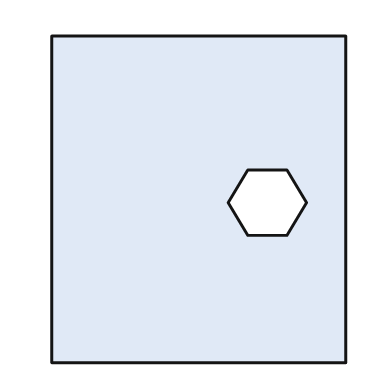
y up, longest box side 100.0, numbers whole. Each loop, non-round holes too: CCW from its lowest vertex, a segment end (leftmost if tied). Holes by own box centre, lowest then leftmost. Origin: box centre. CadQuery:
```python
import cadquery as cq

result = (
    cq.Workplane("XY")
    .moveTo(-45.0, -50.0)
    .lineTo(45.0, -50.0)
    .lineTo(45.0, 50.0)
    .lineTo(-45.0, 50.0)
    .close()
    .moveTo(15.0, -11.0)
    .lineTo(27.0, -11.0)
    .lineTo(33.0, -1.0)
    .lineTo(27.0, 9.0)
    .lineTo(15.0, 9.0)
    .lineTo(9.0, -1.0)
    .close()
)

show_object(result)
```